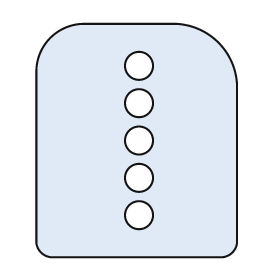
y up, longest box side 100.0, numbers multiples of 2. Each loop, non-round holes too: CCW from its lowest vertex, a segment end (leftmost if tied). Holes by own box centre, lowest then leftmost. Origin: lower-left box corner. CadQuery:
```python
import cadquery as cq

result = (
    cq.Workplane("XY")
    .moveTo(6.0, 0.0)
    .lineTo(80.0, 0.0)
    .threePointArc((84.0, 2.0), (86.0, 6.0))
    .lineTo(86.0, 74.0)
    .threePointArc((78.0, 92.0), (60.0, 100.0))
    .lineTo(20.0, 100.0)
    .threePointArc((6.0, 94.0), (0.0, 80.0))
    .lineTo(0.0, 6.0)
    .threePointArc((2.0, 2.0), (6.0, 0.0))
    .close()
    .moveTo(44.0, 18.0)
    .circle(6.0)
    .moveTo(44.0, 34.0)
    .circle(6.0)
    .moveTo(44.0, 50.0)
    .circle(6.0)
    .moveTo(44.0, 66.0)
    .circle(6.0)
    .moveTo(44.0, 82.0)
    .circle(6.0)
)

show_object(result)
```